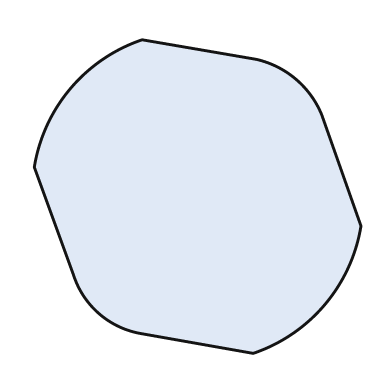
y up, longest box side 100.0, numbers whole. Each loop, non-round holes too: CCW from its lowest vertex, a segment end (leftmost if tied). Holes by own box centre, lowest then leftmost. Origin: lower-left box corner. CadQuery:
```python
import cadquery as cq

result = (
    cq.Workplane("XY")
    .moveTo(67.0, 0.0)
    .threePointArc((89.0, 15.0), (100.0, 39.0))
    .lineTo(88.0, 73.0)
    .threePointArc((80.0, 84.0), (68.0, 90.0))
    .lineTo(33.0, 96.0)
    .threePointArc((11.0, 81.0), (0.0, 57.0))
    .lineTo(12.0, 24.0)
    .threePointArc((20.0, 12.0), (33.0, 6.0))
    .close()
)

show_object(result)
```